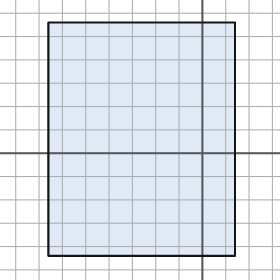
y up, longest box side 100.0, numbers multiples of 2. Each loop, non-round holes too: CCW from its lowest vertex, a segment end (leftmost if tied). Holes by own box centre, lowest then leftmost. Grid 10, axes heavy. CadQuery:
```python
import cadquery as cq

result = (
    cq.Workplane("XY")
    .moveTo(-66.0, -44.0)
    .lineTo(14.0, -44.0)
    .lineTo(14.0, 56.0)
    .lineTo(-66.0, 56.0)
    .close()
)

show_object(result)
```